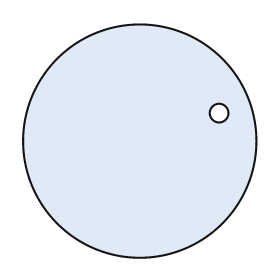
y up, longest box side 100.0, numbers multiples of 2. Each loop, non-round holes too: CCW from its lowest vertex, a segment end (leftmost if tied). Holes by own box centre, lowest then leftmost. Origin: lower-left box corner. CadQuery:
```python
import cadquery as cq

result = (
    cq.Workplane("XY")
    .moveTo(50.0, 50.0)
    .circle(50.0)
    .moveTo(84.0, 62.0)
    .circle(4.0)
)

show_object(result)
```